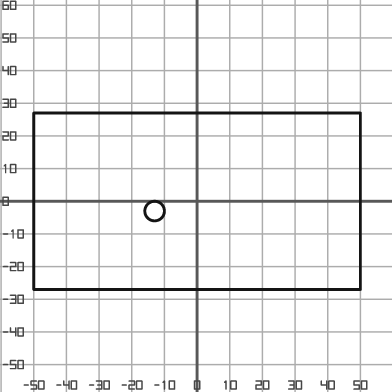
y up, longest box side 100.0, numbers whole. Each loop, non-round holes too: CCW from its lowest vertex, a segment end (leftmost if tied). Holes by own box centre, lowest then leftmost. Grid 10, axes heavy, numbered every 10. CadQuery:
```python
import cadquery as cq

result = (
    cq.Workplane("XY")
    .moveTo(-50.0, -27.0)
    .lineTo(50.0, -27.0)
    .lineTo(50.0, 27.0)
    .lineTo(-50.0, 27.0)
    .close()
    .moveTo(-13.0, -3.0)
    .circle(3.0)
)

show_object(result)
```